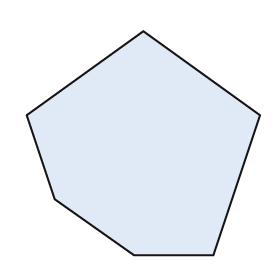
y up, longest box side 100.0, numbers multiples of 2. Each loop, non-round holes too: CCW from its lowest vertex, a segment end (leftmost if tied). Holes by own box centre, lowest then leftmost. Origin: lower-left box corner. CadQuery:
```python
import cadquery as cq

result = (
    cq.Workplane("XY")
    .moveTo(46.0, 0.0)
    .lineTo(80.0, 0.0)
    .lineTo(100.0, 60.0)
    .lineTo(50.0, 96.0)
    .lineTo(0.0, 60.0)
    .lineTo(12.0, 24.0)
    .close()
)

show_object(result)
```